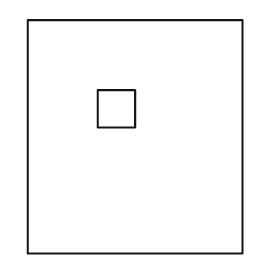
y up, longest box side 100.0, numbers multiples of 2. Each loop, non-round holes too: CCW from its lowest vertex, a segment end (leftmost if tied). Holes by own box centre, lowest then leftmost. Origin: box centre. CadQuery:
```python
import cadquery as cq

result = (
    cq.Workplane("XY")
    .moveTo(-46.0, -50.0)
    .lineTo(46.0, -50.0)
    .lineTo(46.0, 50.0)
    .lineTo(-46.0, 50.0)
    .close()
    .moveTo(-16.0, 4.0)
    .lineTo(0.0, 4.0)
    .lineTo(0.0, 20.0)
    .lineTo(-16.0, 20.0)
    .close()
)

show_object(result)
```